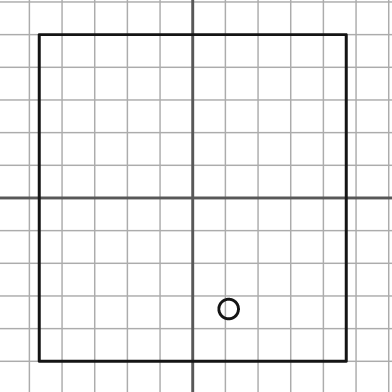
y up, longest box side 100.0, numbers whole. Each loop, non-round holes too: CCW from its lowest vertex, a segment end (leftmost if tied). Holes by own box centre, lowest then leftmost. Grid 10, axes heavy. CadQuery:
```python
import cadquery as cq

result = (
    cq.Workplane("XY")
    .moveTo(-47.0, -50.0)
    .lineTo(47.0, -50.0)
    .lineTo(47.0, 50.0)
    .lineTo(-47.0, 50.0)
    .close()
    .moveTo(11.0, -34.0)
    .circle(3.0)
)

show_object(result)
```